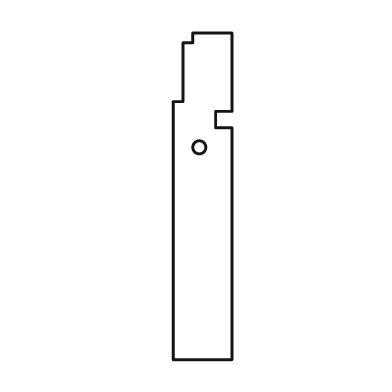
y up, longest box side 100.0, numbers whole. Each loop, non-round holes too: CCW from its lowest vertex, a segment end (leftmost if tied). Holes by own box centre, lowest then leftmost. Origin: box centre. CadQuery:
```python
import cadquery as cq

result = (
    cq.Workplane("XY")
    .moveTo(-9.0, -50.0)
    .lineTo(9.0, -50.0)
    .lineTo(9.0, 21.0)
    .lineTo(4.0, 21.0)
    .lineTo(4.0, 26.0)
    .lineTo(9.0, 26.0)
    .lineTo(9.0, 50.0)
    .lineTo(-3.0, 50.0)
    .lineTo(-3.0, 47.0)
    .lineTo(-6.0, 47.0)
    .lineTo(-6.0, 29.0)
    .lineTo(-9.0, 29.0)
    .close()
    .moveTo(-1.0, 15.0)
    .circle(2.0)
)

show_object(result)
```